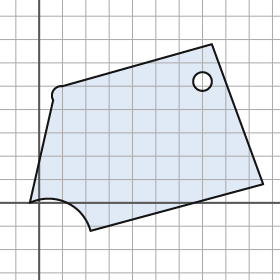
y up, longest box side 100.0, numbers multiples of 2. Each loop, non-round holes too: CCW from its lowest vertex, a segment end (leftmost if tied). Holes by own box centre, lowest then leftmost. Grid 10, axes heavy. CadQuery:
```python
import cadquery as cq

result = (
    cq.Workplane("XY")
    .moveTo(22.0, -12.0)
    .lineTo(96.0, 8.0)
    .lineTo(74.0, 68.0)
    .lineTo(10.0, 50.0)
    .threePointArc((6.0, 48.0), (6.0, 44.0))
    .lineTo(-4.0, 0.0)
    .threePointArc((12.0, 0.0), (22.0, -12.0))
    .close()
    .moveTo(70.0, 52.0)
    .circle(4.0)
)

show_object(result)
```